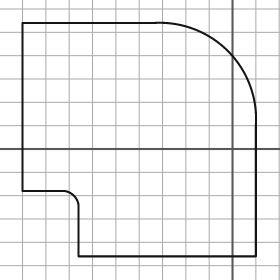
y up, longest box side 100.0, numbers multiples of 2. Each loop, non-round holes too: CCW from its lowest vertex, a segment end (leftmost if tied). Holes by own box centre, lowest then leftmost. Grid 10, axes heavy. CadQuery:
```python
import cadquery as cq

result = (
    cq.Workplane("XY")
    .moveTo(-66.0, -46.0)
    .lineTo(10.0, -46.0)
    .lineTo(10.0, 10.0)
    .threePointArc((-2.0, 42.0), (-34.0, 54.0))
    .lineTo(-90.0, 54.0)
    .lineTo(-90.0, -18.0)
    .lineTo(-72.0, -18.0)
    .threePointArc((-68.0, -20.0), (-66.0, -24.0))
    .close()
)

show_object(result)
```